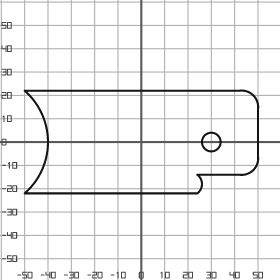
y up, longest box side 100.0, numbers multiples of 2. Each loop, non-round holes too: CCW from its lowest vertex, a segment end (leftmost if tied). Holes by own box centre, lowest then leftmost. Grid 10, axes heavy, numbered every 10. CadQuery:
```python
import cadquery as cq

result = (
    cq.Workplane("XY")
    .moveTo(-50.0, -22.0)
    .lineTo(24.0, -22.0)
    .threePointArc((26.0, -18.0), (24.0, -14.0))
    .lineTo(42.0, -14.0)
    .threePointArc((48.0, -12.0), (50.0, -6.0))
    .lineTo(50.0, 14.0)
    .threePointArc((48.0, 20.0), (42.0, 22.0))
    .lineTo(-50.0, 22.0)
    .threePointArc((-40.0, 0.0), (-50.0, -22.0))
    .close()
    .moveTo(30.0, 0.0)
    .circle(4.0)
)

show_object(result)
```